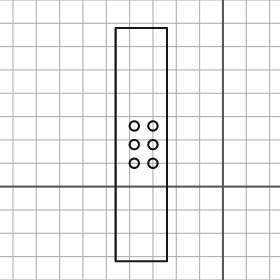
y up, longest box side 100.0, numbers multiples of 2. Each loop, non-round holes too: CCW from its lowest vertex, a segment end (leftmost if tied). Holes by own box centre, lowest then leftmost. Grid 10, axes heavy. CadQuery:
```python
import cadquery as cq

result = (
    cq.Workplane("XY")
    .moveTo(-46.0, -32.0)
    .lineTo(-24.0, -32.0)
    .lineTo(-24.0, 68.0)
    .lineTo(-46.0, 68.0)
    .close()
    .moveTo(-38.0, 10.0)
    .circle(2.0)
    .moveTo(-30.0, 10.0)
    .circle(2.0)
    .moveTo(-38.0, 18.0)
    .circle(2.0)
    .moveTo(-30.0, 18.0)
    .circle(2.0)
    .moveTo(-38.0, 26.0)
    .circle(2.0)
    .moveTo(-30.0, 26.0)
    .circle(2.0)
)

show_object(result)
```